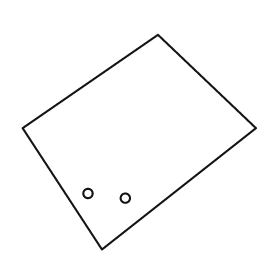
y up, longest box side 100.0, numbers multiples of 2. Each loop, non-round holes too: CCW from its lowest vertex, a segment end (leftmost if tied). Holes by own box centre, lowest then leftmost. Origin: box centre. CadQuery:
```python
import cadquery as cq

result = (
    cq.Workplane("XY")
    .moveTo(-16.0, -46.0)
    .lineTo(50.0, 6.0)
    .lineTo(8.0, 46.0)
    .lineTo(-50.0, 6.0)
    .close()
    .moveTo(-6.0, -24.0)
    .circle(2.0)
    .moveTo(-22.0, -22.0)
    .circle(2.0)
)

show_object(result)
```